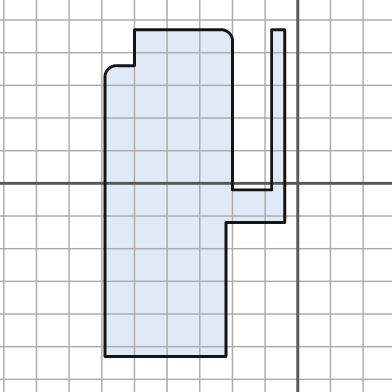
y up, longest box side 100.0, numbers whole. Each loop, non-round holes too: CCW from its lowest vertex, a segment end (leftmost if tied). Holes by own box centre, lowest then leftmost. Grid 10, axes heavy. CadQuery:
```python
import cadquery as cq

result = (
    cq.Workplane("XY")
    .moveTo(-59.0, -53.0)
    .lineTo(-22.0, -53.0)
    .lineTo(-22.0, -12.0)
    .lineTo(-4.0, -12.0)
    .lineTo(-4.0, 47.0)
    .lineTo(-8.0, 47.0)
    .lineTo(-8.0, -2.0)
    .lineTo(-20.0, -2.0)
    .lineTo(-20.0, 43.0)
    .threePointArc((-21.0, 46.0), (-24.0, 47.0))
    .lineTo(-50.0, 47.0)
    .lineTo(-50.0, 36.0)
    .lineTo(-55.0, 36.0)
    .threePointArc((-58.0, 35.0), (-59.0, 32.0))
    .close()
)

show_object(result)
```